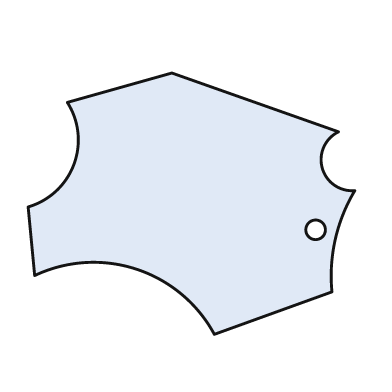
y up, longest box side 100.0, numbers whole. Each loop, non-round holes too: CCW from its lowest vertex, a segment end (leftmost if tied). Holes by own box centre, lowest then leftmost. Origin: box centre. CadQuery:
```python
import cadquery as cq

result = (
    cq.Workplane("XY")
    .moveTo(7.0, -40.0)
    .lineTo(43.0, -27.0)
    .threePointArc((44.0, -11.0), (50.0, 4.0))
    .threePointArc((40.0, 11.0), (45.0, 22.0))
    .lineTo(-6.0, 40.0)
    .lineTo(-38.0, 31.0)
    .threePointArc((-36.0, 12.0), (-50.0, -1.0))
    .lineTo(-48.0, -22.0)
    .threePointArc((-17.0, -20.0), (7.0, -40.0))
    .close()
    .moveTo(38.0, -8.0)
    .circle(3.0)
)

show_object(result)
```